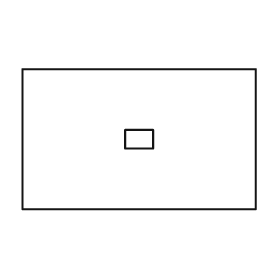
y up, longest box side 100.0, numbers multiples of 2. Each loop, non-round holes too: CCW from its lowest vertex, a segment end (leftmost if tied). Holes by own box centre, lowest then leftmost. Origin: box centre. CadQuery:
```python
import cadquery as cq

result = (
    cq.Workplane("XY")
    .moveTo(-50.0, -30.0)
    .lineTo(50.0, -30.0)
    .lineTo(50.0, 30.0)
    .lineTo(-50.0, 30.0)
    .close()
    .moveTo(-6.0, -4.0)
    .lineTo(6.0, -4.0)
    .lineTo(6.0, 4.0)
    .lineTo(-6.0, 4.0)
    .close()
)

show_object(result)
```